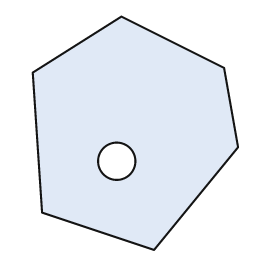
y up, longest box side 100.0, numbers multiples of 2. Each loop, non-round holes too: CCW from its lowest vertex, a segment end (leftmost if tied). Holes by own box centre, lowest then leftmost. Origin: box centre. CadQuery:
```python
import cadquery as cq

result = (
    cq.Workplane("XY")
    .moveTo(8.0, -50.0)
    .lineTo(44.0, -6.0)
    .lineTo(38.0, 28.0)
    .lineTo(-6.0, 50.0)
    .lineTo(-44.0, 26.0)
    .lineTo(-40.0, -34.0)
    .close()
    .moveTo(-8.0, -12.0)
    .circle(8.0)
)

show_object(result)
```